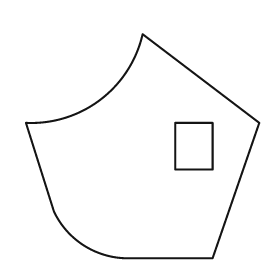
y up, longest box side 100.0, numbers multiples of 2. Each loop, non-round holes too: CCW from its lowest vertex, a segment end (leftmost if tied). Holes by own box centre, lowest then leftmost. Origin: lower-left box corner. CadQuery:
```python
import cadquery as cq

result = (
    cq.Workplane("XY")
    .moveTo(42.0, 0.0)
    .lineTo(80.0, 0.0)
    .lineTo(100.0, 58.0)
    .lineTo(50.0, 96.0)
    .threePointArc((32.0, 68.0), (0.0, 58.0))
    .lineTo(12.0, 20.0)
    .threePointArc((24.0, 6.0), (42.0, 0.0))
    .close()
    .moveTo(64.0, 38.0)
    .lineTo(80.0, 38.0)
    .lineTo(80.0, 58.0)
    .lineTo(64.0, 58.0)
    .close()
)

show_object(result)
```